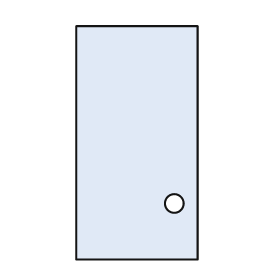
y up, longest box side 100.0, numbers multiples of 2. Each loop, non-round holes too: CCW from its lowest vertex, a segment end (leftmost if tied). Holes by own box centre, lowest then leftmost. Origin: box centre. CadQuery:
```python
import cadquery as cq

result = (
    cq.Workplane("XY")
    .moveTo(-26.0, -50.0)
    .lineTo(26.0, -50.0)
    .lineTo(26.0, 50.0)
    .lineTo(-26.0, 50.0)
    .close()
    .moveTo(16.0, -26.0)
    .circle(4.0)
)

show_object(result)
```